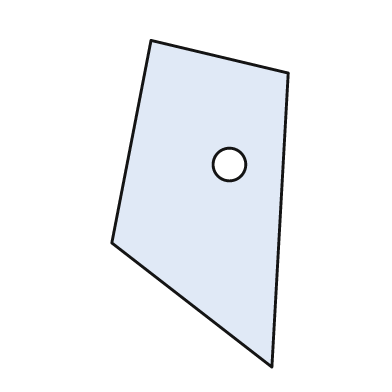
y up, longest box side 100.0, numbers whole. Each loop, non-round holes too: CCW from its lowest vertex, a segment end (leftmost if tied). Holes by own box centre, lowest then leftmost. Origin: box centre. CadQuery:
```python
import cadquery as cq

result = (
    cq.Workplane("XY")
    .moveTo(22.0, -50.0)
    .lineTo(27.0, 40.0)
    .lineTo(-15.0, 50.0)
    .lineTo(-27.0, -12.0)
    .close()
    .moveTo(9.0, 12.0)
    .circle(5.0)
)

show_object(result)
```